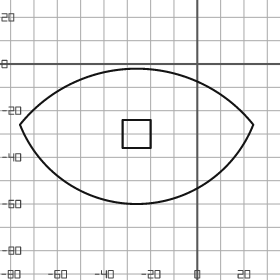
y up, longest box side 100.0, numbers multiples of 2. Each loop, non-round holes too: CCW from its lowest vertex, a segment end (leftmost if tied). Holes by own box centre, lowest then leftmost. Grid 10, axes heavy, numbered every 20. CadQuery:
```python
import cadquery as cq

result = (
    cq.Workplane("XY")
    .moveTo(-76.0, -26.0)
    .threePointArc((-26.0, -60.0), (24.0, -26.0))
    .threePointArc((-26.0, -2.0), (-76.0, -26.0))
    .close()
    .moveTo(-32.0, -36.0)
    .lineTo(-20.0, -36.0)
    .lineTo(-20.0, -24.0)
    .lineTo(-32.0, -24.0)
    .close()
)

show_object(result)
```